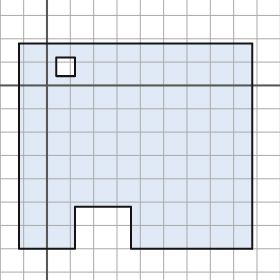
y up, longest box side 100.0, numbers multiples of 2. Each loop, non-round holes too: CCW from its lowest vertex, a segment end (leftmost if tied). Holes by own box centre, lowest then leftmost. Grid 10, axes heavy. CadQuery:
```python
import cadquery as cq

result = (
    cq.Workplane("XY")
    .moveTo(-12.0, -70.0)
    .lineTo(12.0, -70.0)
    .lineTo(12.0, -52.0)
    .lineTo(36.0, -52.0)
    .lineTo(36.0, -70.0)
    .lineTo(88.0, -70.0)
    .lineTo(88.0, 18.0)
    .lineTo(-12.0, 18.0)
    .close()
    .moveTo(4.0, 4.0)
    .lineTo(12.0, 4.0)
    .lineTo(12.0, 12.0)
    .lineTo(4.0, 12.0)
    .close()
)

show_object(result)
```